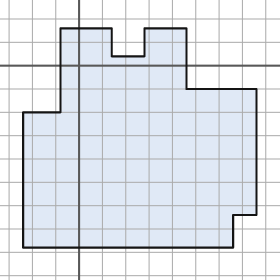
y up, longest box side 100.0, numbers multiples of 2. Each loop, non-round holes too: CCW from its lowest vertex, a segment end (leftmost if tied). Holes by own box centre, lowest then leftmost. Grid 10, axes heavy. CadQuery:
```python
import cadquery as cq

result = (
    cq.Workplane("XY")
    .moveTo(-24.0, -78.0)
    .lineTo(66.0, -78.0)
    .lineTo(66.0, -64.0)
    .lineTo(76.0, -64.0)
    .lineTo(76.0, -10.0)
    .lineTo(46.0, -10.0)
    .lineTo(46.0, 16.0)
    .lineTo(28.0, 16.0)
    .lineTo(28.0, 4.0)
    .lineTo(14.0, 4.0)
    .lineTo(14.0, 16.0)
    .lineTo(-8.0, 16.0)
    .lineTo(-8.0, -20.0)
    .lineTo(-24.0, -20.0)
    .close()
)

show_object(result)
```